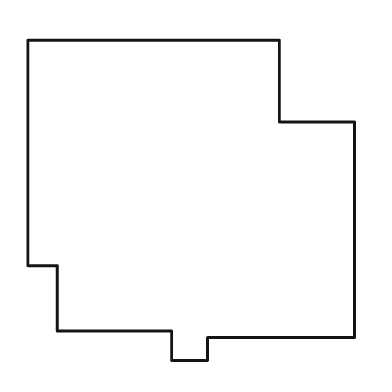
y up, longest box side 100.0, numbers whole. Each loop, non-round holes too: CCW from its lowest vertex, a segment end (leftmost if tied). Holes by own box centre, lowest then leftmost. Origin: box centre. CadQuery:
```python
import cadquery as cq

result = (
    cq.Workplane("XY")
    .moveTo(-6.0, -49.0)
    .lineTo(5.0, -49.0)
    .lineTo(5.0, -42.0)
    .lineTo(50.0, -42.0)
    .lineTo(50.0, 24.0)
    .lineTo(27.0, 24.0)
    .lineTo(27.0, 49.0)
    .lineTo(-50.0, 49.0)
    .lineTo(-50.0, -20.0)
    .lineTo(-41.0, -20.0)
    .lineTo(-41.0, -40.0)
    .lineTo(-6.0, -40.0)
    .close()
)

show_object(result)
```